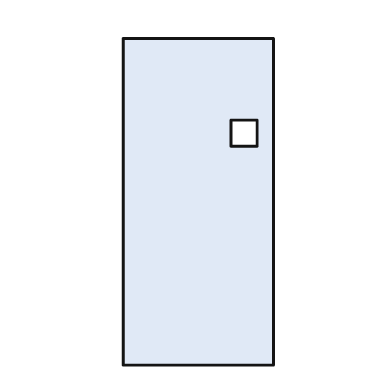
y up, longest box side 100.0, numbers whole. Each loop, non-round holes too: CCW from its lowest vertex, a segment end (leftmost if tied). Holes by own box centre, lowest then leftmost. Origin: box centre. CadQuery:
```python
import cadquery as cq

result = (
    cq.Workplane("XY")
    .moveTo(-23.0, -50.0)
    .lineTo(23.0, -50.0)
    .lineTo(23.0, 50.0)
    .lineTo(-23.0, 50.0)
    .close()
    .moveTo(10.0, 17.0)
    .lineTo(18.0, 17.0)
    .lineTo(18.0, 25.0)
    .lineTo(10.0, 25.0)
    .close()
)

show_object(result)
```